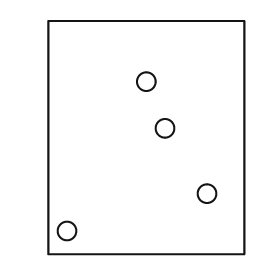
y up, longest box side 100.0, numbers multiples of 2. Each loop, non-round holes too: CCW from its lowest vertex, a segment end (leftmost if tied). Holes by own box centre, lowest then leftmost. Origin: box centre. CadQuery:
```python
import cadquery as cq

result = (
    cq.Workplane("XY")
    .moveTo(-42.0, -50.0)
    .lineTo(42.0, -50.0)
    .lineTo(42.0, 50.0)
    .lineTo(-42.0, 50.0)
    .close()
    .moveTo(-34.0, -40.0)
    .circle(4.0)
    .moveTo(26.0, -24.0)
    .circle(4.0)
    .moveTo(8.0, 4.0)
    .circle(4.0)
    .moveTo(0.0, 24.0)
    .circle(4.0)
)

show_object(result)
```